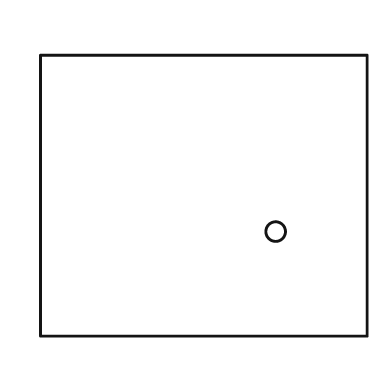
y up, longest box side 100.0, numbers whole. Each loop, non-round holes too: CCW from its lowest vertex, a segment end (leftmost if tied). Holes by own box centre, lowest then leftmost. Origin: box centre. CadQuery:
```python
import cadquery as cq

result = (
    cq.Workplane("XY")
    .moveTo(-50.0, -43.0)
    .lineTo(50.0, -43.0)
    .lineTo(50.0, 43.0)
    .lineTo(-50.0, 43.0)
    .close()
    .moveTo(22.0, -11.0)
    .circle(3.0)
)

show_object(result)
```